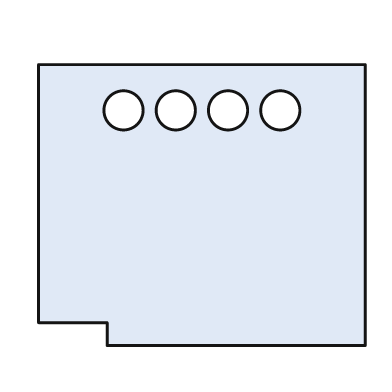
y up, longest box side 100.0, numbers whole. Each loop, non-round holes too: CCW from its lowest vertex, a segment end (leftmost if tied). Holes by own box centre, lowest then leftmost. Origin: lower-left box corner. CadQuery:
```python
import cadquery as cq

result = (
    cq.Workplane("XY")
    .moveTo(21.0, 0.0)
    .lineTo(100.0, 0.0)
    .lineTo(100.0, 86.0)
    .lineTo(0.0, 86.0)
    .lineTo(0.0, 7.0)
    .lineTo(21.0, 7.0)
    .close()
    .moveTo(26.0, 72.0)
    .circle(6.0)
    .moveTo(42.0, 72.0)
    .circle(6.0)
    .moveTo(58.0, 72.0)
    .circle(6.0)
    .moveTo(74.0, 72.0)
    .circle(6.0)
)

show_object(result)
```